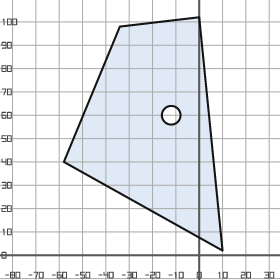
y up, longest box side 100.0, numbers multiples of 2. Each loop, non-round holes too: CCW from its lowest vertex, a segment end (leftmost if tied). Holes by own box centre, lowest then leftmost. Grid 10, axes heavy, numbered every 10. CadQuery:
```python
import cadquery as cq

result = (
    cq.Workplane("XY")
    .moveTo(10.0, 2.0)
    .lineTo(0.0, 102.0)
    .lineTo(-34.0, 98.0)
    .lineTo(-58.0, 40.0)
    .close()
    .moveTo(-12.0, 60.0)
    .circle(4.0)
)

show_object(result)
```